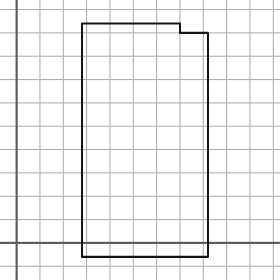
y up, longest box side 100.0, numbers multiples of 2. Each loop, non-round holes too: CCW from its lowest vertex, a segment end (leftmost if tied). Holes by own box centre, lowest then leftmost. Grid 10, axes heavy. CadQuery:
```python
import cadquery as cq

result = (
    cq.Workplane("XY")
    .moveTo(28.0, -6.0)
    .lineTo(82.0, -6.0)
    .lineTo(82.0, 90.0)
    .lineTo(70.0, 90.0)
    .lineTo(70.0, 94.0)
    .lineTo(28.0, 94.0)
    .close()
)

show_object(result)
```